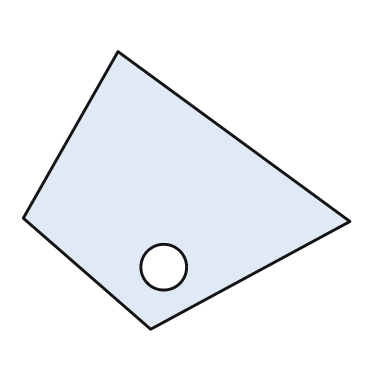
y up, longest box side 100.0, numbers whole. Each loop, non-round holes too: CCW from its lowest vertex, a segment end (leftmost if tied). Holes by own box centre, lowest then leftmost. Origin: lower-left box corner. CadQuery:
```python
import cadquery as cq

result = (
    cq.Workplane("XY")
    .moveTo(39.0, 0.0)
    .lineTo(100.0, 33.0)
    .lineTo(29.0, 85.0)
    .lineTo(0.0, 34.0)
    .close()
    .moveTo(43.0, 19.0)
    .circle(7.0)
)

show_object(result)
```